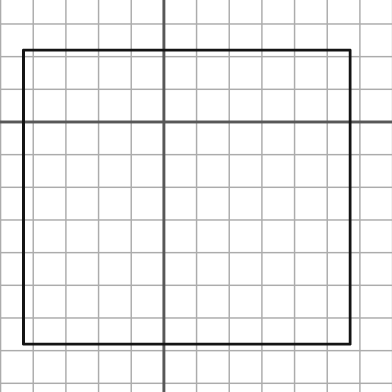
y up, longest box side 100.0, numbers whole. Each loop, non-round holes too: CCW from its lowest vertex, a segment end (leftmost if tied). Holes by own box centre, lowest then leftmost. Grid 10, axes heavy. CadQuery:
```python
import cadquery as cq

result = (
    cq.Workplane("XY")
    .moveTo(-43.0, -68.0)
    .lineTo(57.0, -68.0)
    .lineTo(57.0, 22.0)
    .lineTo(-43.0, 22.0)
    .close()
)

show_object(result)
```